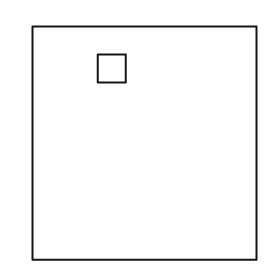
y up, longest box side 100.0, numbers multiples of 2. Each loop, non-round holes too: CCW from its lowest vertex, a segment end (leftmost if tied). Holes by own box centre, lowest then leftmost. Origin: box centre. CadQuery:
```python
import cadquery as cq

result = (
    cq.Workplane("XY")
    .moveTo(-48.0, -50.0)
    .lineTo(48.0, -50.0)
    .lineTo(48.0, 50.0)
    .lineTo(-48.0, 50.0)
    .close()
    .moveTo(-20.0, 26.0)
    .lineTo(-8.0, 26.0)
    .lineTo(-8.0, 38.0)
    .lineTo(-20.0, 38.0)
    .close()
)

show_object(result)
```